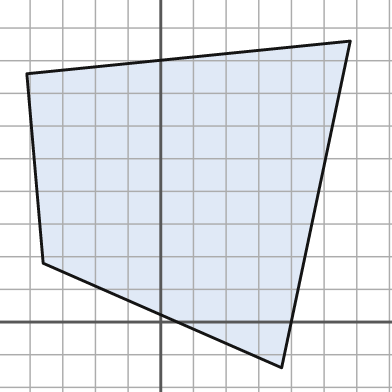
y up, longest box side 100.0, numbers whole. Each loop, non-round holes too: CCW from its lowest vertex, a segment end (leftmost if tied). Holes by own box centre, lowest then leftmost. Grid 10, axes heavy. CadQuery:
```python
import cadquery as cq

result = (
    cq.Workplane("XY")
    .moveTo(37.0, -14.0)
    .lineTo(58.0, 86.0)
    .lineTo(-41.0, 76.0)
    .lineTo(-36.0, 18.0)
    .close()
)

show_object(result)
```